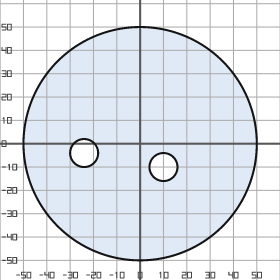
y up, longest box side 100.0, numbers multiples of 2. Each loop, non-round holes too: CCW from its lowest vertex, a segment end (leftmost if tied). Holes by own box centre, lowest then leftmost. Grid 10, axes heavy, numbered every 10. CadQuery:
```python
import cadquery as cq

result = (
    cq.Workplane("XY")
    .moveTo(0.0, 0.0)
    .circle(50.0)
    .moveTo(10.0, -10.0)
    .circle(6.0)
    .moveTo(-24.0, -4.0)
    .circle(6.0)
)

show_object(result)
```